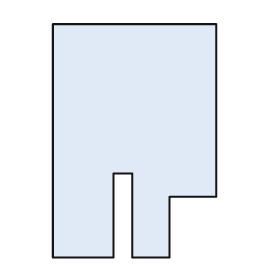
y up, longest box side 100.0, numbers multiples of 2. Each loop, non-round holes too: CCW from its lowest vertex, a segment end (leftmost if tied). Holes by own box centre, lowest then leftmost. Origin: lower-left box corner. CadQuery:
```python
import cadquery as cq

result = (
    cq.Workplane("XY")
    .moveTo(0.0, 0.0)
    .lineTo(26.0, 0.0)
    .lineTo(26.0, 36.0)
    .lineTo(34.0, 36.0)
    .lineTo(34.0, 0.0)
    .lineTo(50.0, 0.0)
    .lineTo(50.0, 26.0)
    .lineTo(70.0, 26.0)
    .lineTo(70.0, 100.0)
    .lineTo(0.0, 100.0)
    .close()
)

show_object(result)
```